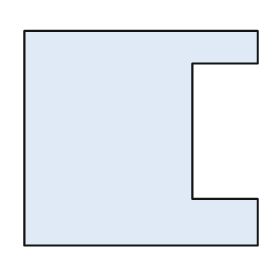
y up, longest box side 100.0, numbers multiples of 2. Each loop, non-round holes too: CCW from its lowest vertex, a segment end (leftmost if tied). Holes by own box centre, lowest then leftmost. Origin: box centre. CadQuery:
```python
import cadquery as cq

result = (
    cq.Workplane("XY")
    .moveTo(-50.0, -46.0)
    .lineTo(50.0, -46.0)
    .lineTo(50.0, -26.0)
    .lineTo(22.0, -26.0)
    .lineTo(22.0, 32.0)
    .lineTo(50.0, 32.0)
    .lineTo(50.0, 46.0)
    .lineTo(-50.0, 46.0)
    .close()
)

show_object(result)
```